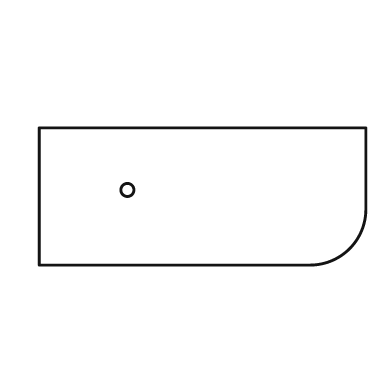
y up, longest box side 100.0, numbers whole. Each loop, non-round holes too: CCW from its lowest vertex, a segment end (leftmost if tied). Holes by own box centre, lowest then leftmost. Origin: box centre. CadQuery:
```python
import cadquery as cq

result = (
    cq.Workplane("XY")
    .moveTo(-50.0, -21.0)
    .lineTo(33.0, -21.0)
    .threePointArc((45.0, -16.0), (50.0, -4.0))
    .lineTo(50.0, 21.0)
    .lineTo(-50.0, 21.0)
    .close()
    .moveTo(-23.0, 2.0)
    .circle(2.0)
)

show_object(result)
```